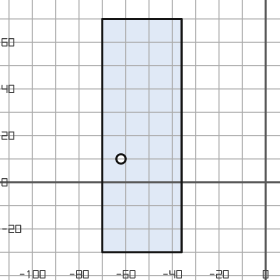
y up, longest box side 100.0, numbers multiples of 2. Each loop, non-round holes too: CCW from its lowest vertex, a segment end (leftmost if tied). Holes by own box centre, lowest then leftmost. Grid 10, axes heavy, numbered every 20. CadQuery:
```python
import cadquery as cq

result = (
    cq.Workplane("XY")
    .moveTo(-70.0, -30.0)
    .lineTo(-36.0, -30.0)
    .lineTo(-36.0, 70.0)
    .lineTo(-70.0, 70.0)
    .close()
    .moveTo(-62.0, 10.0)
    .circle(2.0)
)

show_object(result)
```